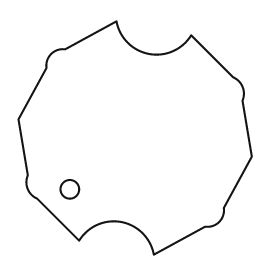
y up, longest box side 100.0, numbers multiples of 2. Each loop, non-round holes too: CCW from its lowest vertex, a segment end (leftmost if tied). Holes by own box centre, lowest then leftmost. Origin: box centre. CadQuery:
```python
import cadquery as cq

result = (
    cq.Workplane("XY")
    .moveTo(8.0, -50.0)
    .lineTo(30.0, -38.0)
    .threePointArc((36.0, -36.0), (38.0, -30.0))
    .lineTo(50.0, -8.0)
    .lineTo(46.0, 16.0)
    .threePointArc((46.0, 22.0), (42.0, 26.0))
    .lineTo(24.0, 44.0)
    .threePointArc((6.0, 36.0), (-8.0, 50.0))
    .lineTo(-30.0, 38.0)
    .threePointArc((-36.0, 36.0), (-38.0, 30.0))
    .lineTo(-50.0, 8.0)
    .lineTo(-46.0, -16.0)
    .threePointArc((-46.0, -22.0), (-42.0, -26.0))
    .lineTo(-24.0, -44.0)
    .threePointArc((-6.0, -36.0), (8.0, -50.0))
    .close()
    .moveTo(-28.0, -22.0)
    .circle(4.0)
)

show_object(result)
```